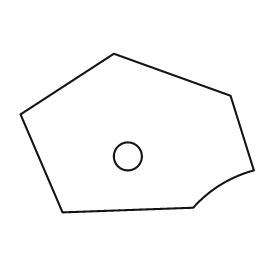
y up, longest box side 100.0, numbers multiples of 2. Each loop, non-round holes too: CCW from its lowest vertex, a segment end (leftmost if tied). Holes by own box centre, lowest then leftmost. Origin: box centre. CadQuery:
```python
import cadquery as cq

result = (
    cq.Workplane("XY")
    .moveTo(-32.0, -34.0)
    .lineTo(24.0, -32.0)
    .threePointArc((36.0, -22.0), (50.0, -16.0))
    .lineTo(40.0, 16.0)
    .lineTo(-10.0, 34.0)
    .lineTo(-50.0, 8.0)
    .close()
    .moveTo(-4.0, -10.0)
    .circle(6.0)
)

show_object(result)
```